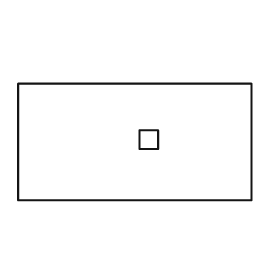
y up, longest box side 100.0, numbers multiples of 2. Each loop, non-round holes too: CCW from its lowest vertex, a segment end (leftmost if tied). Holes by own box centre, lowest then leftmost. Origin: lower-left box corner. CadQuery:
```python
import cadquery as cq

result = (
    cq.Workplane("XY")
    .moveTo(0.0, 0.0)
    .lineTo(100.0, 0.0)
    .lineTo(100.0, 50.0)
    .lineTo(0.0, 50.0)
    .close()
    .moveTo(52.0, 22.0)
    .lineTo(60.0, 22.0)
    .lineTo(60.0, 30.0)
    .lineTo(52.0, 30.0)
    .close()
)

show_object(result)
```